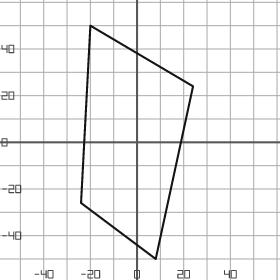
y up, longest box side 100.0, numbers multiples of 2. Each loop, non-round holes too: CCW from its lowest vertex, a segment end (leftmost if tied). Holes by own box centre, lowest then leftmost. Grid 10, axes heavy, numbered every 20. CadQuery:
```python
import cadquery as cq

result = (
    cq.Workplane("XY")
    .moveTo(8.0, -50.0)
    .lineTo(24.0, 24.0)
    .lineTo(-20.0, 50.0)
    .lineTo(-24.0, -26.0)
    .close()
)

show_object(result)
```